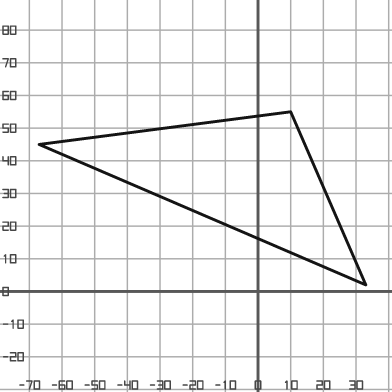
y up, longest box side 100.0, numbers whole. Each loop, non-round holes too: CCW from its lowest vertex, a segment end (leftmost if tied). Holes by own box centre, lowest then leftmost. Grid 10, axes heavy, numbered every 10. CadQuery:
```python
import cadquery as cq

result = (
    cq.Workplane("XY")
    .moveTo(33.0, 2.0)
    .lineTo(10.0, 55.0)
    .lineTo(-67.0, 45.0)
    .close()
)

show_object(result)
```